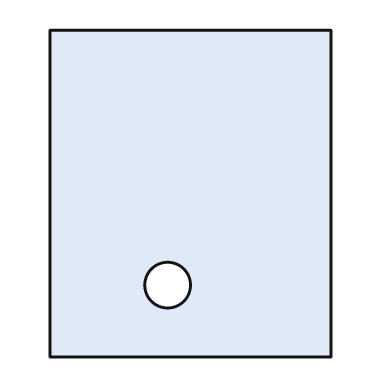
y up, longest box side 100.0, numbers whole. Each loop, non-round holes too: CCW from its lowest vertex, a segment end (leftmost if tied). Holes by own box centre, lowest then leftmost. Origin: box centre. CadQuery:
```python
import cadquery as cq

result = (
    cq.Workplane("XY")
    .moveTo(-43.0, -50.0)
    .lineTo(43.0, -50.0)
    .lineTo(43.0, 50.0)
    .lineTo(-43.0, 50.0)
    .close()
    .moveTo(-7.0, -28.0)
    .circle(7.0)
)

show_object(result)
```